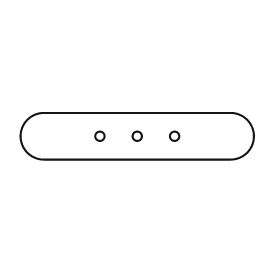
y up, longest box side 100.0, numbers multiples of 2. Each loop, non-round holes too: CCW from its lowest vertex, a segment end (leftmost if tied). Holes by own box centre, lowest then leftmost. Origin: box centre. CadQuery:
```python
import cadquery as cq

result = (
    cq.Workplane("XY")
    .moveTo(-40.0, -10.0)
    .lineTo(40.0, -10.0)
    .threePointArc((50.0, 0.0), (40.0, 10.0))
    .lineTo(-40.0, 10.0)
    .threePointArc((-50.0, 0.0), (-40.0, -10.0))
    .close()
    .moveTo(-16.0, 0.0)
    .circle(2.0)
    .moveTo(0.0, 0.0)
    .circle(2.0)
    .moveTo(16.0, 0.0)
    .circle(2.0)
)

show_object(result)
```